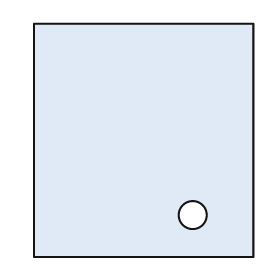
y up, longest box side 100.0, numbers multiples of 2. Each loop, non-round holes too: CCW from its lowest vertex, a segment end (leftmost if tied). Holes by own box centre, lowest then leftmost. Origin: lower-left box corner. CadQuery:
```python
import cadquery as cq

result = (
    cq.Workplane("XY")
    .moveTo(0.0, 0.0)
    .lineTo(94.0, 0.0)
    .lineTo(94.0, 100.0)
    .lineTo(0.0, 100.0)
    .close()
    .moveTo(68.0, 18.0)
    .circle(6.0)
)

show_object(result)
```